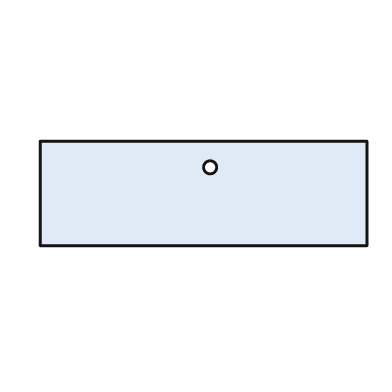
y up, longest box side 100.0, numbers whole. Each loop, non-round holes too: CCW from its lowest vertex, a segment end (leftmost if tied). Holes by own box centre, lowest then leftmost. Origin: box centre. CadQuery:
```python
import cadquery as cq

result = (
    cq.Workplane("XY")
    .moveTo(-50.0, -16.0)
    .lineTo(50.0, -16.0)
    .lineTo(50.0, 16.0)
    .lineTo(-50.0, 16.0)
    .close()
    .moveTo(2.0, 8.0)
    .circle(2.0)
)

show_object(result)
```